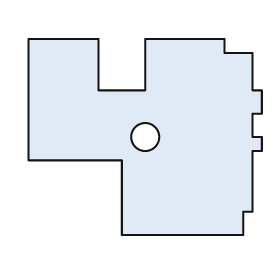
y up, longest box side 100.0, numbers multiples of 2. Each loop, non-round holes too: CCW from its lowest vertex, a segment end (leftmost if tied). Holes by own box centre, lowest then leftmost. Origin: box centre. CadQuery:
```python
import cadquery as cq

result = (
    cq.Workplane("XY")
    .moveTo(-10.0, -42.0)
    .lineTo(42.0, -42.0)
    .lineTo(42.0, -32.0)
    .lineTo(46.0, -32.0)
    .lineTo(46.0, -6.0)
    .lineTo(50.0, -6.0)
    .lineTo(50.0, 0.0)
    .lineTo(46.0, 0.0)
    .lineTo(46.0, 10.0)
    .lineTo(50.0, 10.0)
    .lineTo(50.0, 20.0)
    .lineTo(46.0, 20.0)
    .lineTo(46.0, 36.0)
    .lineTo(34.0, 36.0)
    .lineTo(34.0, 42.0)
    .lineTo(0.0, 42.0)
    .lineTo(0.0, 20.0)
    .lineTo(-20.0, 20.0)
    .lineTo(-20.0, 42.0)
    .lineTo(-50.0, 42.0)
    .lineTo(-50.0, -10.0)
    .lineTo(-10.0, -10.0)
    .close()
    .moveTo(0.0, 0.0)
    .circle(6.0)
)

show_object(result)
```